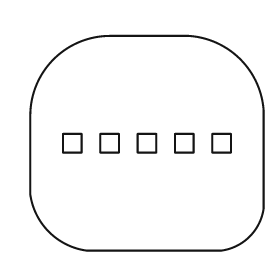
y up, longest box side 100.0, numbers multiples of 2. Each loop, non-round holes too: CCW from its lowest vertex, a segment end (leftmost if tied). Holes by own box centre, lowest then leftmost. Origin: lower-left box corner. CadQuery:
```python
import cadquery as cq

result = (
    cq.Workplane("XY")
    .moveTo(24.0, 0.0)
    .lineTo(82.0, 0.0)
    .threePointArc((94.0, 6.0), (100.0, 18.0))
    .lineTo(100.0, 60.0)
    .threePointArc((90.0, 82.0), (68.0, 92.0))
    .lineTo(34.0, 92.0)
    .threePointArc((10.0, 82.0), (0.0, 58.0))
    .lineTo(0.0, 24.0)
    .threePointArc((8.0, 8.0), (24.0, 0.0))
    .close()
    .moveTo(14.0, 42.0)
    .lineTo(22.0, 42.0)
    .lineTo(22.0, 50.0)
    .lineTo(14.0, 50.0)
    .close()
    .moveTo(30.0, 42.0)
    .lineTo(38.0, 42.0)
    .lineTo(38.0, 50.0)
    .lineTo(30.0, 50.0)
    .close()
    .moveTo(46.0, 42.0)
    .lineTo(54.0, 42.0)
    .lineTo(54.0, 50.0)
    .lineTo(46.0, 50.0)
    .close()
    .moveTo(62.0, 42.0)
    .lineTo(70.0, 42.0)
    .lineTo(70.0, 50.0)
    .lineTo(62.0, 50.0)
    .close()
    .moveTo(78.0, 42.0)
    .lineTo(86.0, 42.0)
    .lineTo(86.0, 50.0)
    .lineTo(78.0, 50.0)
    .close()
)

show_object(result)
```